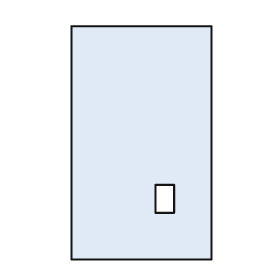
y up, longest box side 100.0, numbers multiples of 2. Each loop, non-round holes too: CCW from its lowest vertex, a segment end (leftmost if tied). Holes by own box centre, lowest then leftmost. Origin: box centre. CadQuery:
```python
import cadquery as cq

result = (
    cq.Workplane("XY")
    .moveTo(-30.0, -50.0)
    .lineTo(30.0, -50.0)
    .lineTo(30.0, 50.0)
    .lineTo(-30.0, 50.0)
    .close()
    .moveTo(6.0, -30.0)
    .lineTo(14.0, -30.0)
    .lineTo(14.0, -18.0)
    .lineTo(6.0, -18.0)
    .close()
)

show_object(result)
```